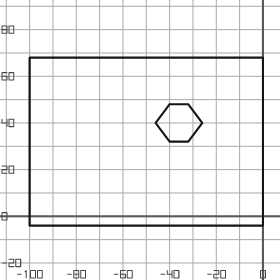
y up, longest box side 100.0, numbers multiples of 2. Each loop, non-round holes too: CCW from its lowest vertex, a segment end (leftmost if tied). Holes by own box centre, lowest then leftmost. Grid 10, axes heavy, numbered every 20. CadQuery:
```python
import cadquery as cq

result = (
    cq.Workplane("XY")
    .moveTo(-100.0, -4.0)
    .lineTo(0.0, -4.0)
    .lineTo(0.0, 68.0)
    .lineTo(-100.0, 68.0)
    .close()
    .moveTo(-40.0, 32.0)
    .lineTo(-32.0, 32.0)
    .lineTo(-26.0, 40.0)
    .lineTo(-32.0, 48.0)
    .lineTo(-40.0, 48.0)
    .lineTo(-46.0, 40.0)
    .close()
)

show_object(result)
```